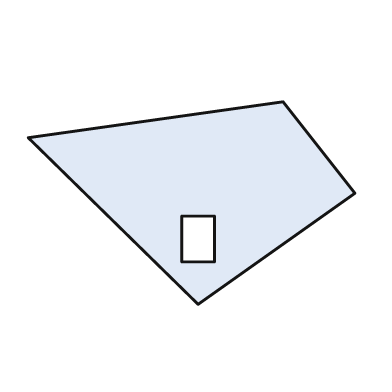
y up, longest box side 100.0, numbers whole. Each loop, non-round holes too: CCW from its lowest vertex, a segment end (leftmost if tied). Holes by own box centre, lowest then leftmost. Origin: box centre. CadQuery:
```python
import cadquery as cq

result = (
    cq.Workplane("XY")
    .moveTo(2.0, -31.0)
    .lineTo(50.0, 3.0)
    .lineTo(28.0, 31.0)
    .lineTo(-50.0, 20.0)
    .close()
    .moveTo(-3.0, -18.0)
    .lineTo(7.0, -18.0)
    .lineTo(7.0, -4.0)
    .lineTo(-3.0, -4.0)
    .close()
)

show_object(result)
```